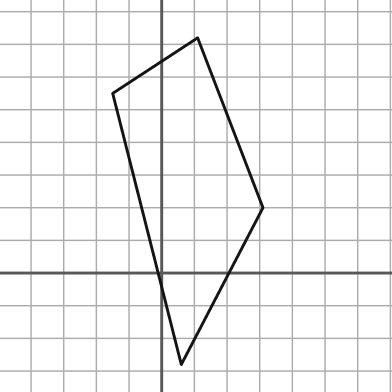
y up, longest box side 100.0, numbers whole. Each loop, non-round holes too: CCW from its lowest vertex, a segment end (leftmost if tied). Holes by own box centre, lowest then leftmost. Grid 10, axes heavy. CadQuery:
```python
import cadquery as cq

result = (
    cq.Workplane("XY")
    .moveTo(6.0, -28.0)
    .lineTo(31.0, 20.0)
    .lineTo(11.0, 72.0)
    .lineTo(-15.0, 55.0)
    .close()
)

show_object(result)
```